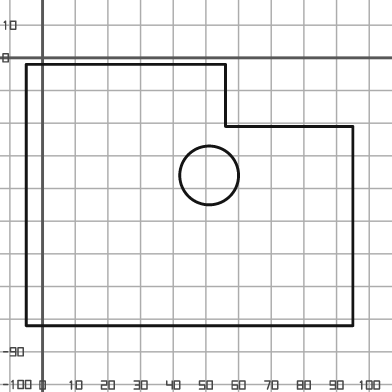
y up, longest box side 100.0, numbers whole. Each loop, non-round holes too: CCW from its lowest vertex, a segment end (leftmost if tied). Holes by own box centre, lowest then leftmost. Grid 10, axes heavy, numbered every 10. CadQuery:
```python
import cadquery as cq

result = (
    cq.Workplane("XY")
    .moveTo(-5.0, -82.0)
    .lineTo(95.0, -82.0)
    .lineTo(95.0, -21.0)
    .lineTo(56.0, -21.0)
    .lineTo(56.0, -2.0)
    .lineTo(-5.0, -2.0)
    .close()
    .moveTo(51.0, -36.0)
    .circle(9.0)
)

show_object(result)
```